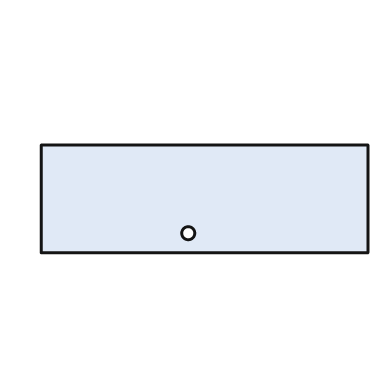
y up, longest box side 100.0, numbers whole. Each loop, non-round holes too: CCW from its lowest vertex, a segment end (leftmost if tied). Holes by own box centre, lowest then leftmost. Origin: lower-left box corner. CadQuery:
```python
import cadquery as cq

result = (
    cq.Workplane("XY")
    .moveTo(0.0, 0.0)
    .lineTo(100.0, 0.0)
    .lineTo(100.0, 33.0)
    .lineTo(0.0, 33.0)
    .close()
    .moveTo(45.0, 6.0)
    .circle(2.0)
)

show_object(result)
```